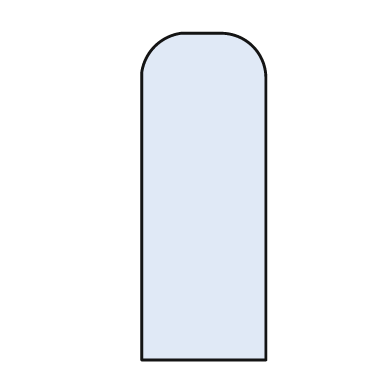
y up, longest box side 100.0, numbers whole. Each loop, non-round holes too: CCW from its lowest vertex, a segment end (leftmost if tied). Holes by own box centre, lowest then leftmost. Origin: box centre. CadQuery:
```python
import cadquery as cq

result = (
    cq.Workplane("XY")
    .moveTo(-19.0, -50.0)
    .lineTo(19.0, -50.0)
    .lineTo(19.0, 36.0)
    .threePointArc((15.0, 46.0), (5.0, 50.0))
    .lineTo(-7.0, 50.0)
    .threePointArc((-15.0, 46.0), (-19.0, 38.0))
    .close()
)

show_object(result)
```